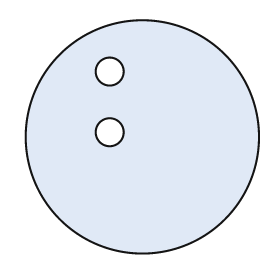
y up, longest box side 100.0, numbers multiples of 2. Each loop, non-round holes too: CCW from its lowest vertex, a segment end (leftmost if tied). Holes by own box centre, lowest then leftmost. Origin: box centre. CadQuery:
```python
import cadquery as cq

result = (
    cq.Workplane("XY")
    .moveTo(0.0, 0.0)
    .circle(50.0)
    .moveTo(-14.0, 2.0)
    .circle(6.0)
    .moveTo(-14.0, 28.0)
    .circle(6.0)
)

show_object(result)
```